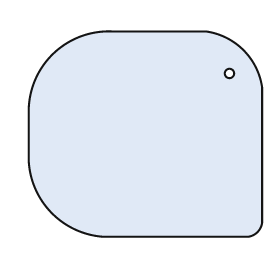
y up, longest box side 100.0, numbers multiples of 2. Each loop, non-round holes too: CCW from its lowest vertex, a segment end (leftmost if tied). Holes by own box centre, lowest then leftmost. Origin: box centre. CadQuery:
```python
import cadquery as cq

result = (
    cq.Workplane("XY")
    .moveTo(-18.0, -44.0)
    .lineTo(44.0, -44.0)
    .threePointArc((48.0, -42.0), (50.0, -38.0))
    .lineTo(50.0, 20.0)
    .threePointArc((42.0, 36.0), (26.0, 44.0))
    .lineTo(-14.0, 44.0)
    .threePointArc((-40.0, 34.0), (-50.0, 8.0))
    .lineTo(-50.0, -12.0)
    .threePointArc((-40.0, -34.0), (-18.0, -44.0))
    .close()
    .moveTo(36.0, 26.0)
    .circle(2.0)
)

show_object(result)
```